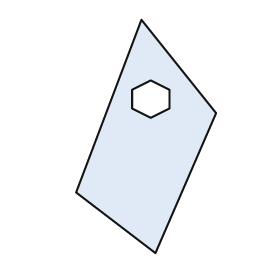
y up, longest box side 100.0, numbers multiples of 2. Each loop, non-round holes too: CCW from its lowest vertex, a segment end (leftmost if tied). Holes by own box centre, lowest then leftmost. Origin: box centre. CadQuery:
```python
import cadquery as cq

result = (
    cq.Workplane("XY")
    .moveTo(4.0, -50.0)
    .lineTo(30.0, 10.0)
    .lineTo(-2.0, 50.0)
    .lineTo(-30.0, -24.0)
    .close()
    .moveTo(2.0, 8.0)
    .lineTo(10.0, 12.0)
    .lineTo(10.0, 20.0)
    .lineTo(2.0, 24.0)
    .lineTo(-6.0, 20.0)
    .lineTo(-6.0, 12.0)
    .close()
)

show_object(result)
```